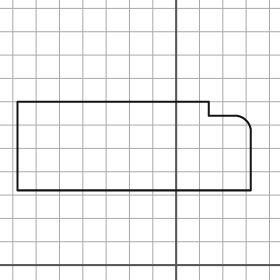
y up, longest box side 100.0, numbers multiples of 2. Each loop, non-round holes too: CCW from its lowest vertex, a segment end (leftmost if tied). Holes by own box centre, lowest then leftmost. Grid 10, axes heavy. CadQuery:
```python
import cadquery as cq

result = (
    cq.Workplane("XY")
    .moveTo(-68.0, 32.0)
    .lineTo(32.0, 32.0)
    .lineTo(32.0, 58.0)
    .threePointArc((30.0, 62.0), (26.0, 64.0))
    .lineTo(14.0, 64.0)
    .lineTo(14.0, 70.0)
    .lineTo(-68.0, 70.0)
    .close()
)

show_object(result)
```